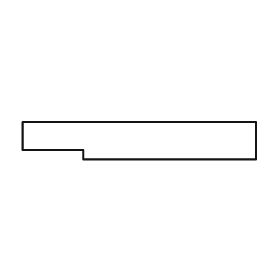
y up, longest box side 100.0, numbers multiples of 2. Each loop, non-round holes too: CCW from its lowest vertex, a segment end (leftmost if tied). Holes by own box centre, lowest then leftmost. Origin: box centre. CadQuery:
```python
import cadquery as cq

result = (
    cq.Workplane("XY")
    .moveTo(-24.0, -8.0)
    .lineTo(50.0, -8.0)
    .lineTo(50.0, 8.0)
    .lineTo(-50.0, 8.0)
    .lineTo(-50.0, -4.0)
    .lineTo(-24.0, -4.0)
    .close()
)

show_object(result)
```